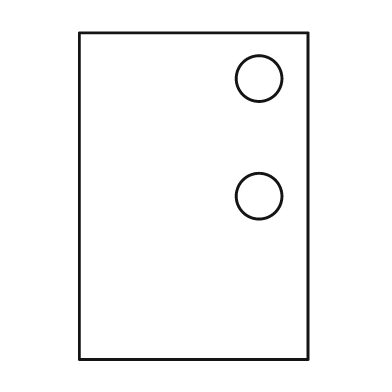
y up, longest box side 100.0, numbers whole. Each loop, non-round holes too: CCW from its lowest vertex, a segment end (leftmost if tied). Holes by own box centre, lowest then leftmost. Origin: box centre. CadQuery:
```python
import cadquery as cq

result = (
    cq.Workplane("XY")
    .moveTo(-35.0, -50.0)
    .lineTo(35.0, -50.0)
    .lineTo(35.0, 50.0)
    .lineTo(-35.0, 50.0)
    .close()
    .moveTo(20.0, 0.0)
    .circle(7.0)
    .moveTo(20.0, 36.0)
    .circle(7.0)
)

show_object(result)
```